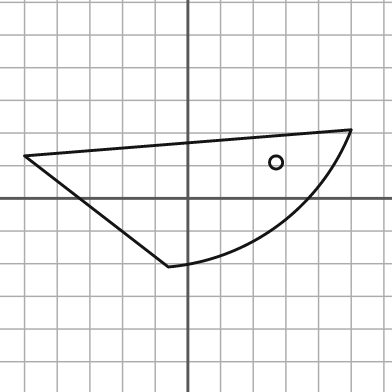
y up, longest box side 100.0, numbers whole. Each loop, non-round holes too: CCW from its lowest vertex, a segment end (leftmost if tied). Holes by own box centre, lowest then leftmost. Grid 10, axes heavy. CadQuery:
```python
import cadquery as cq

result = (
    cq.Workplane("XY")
    .moveTo(-6.0, -21.0)
    .threePointArc((28.0, -8.0), (50.0, 21.0))
    .lineTo(-50.0, 13.0)
    .close()
    .moveTo(27.0, 11.0)
    .circle(2.0)
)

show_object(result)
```